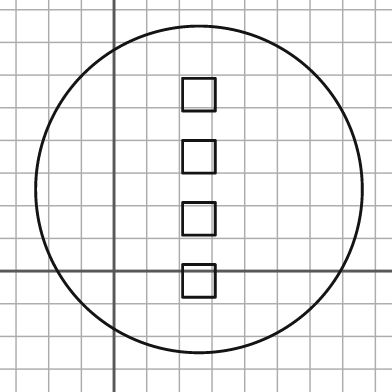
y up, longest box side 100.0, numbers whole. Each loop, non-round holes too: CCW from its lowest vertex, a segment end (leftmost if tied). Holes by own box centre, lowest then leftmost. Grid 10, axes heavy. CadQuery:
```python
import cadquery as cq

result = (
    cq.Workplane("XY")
    .moveTo(26.0, 25.0)
    .circle(50.0)
    .moveTo(21.0, -8.0)
    .lineTo(31.0, -8.0)
    .lineTo(31.0, 2.0)
    .lineTo(21.0, 2.0)
    .close()
    .moveTo(21.0, 11.0)
    .lineTo(31.0, 11.0)
    .lineTo(31.0, 21.0)
    .lineTo(21.0, 21.0)
    .close()
    .moveTo(21.0, 30.0)
    .lineTo(31.0, 30.0)
    .lineTo(31.0, 40.0)
    .lineTo(21.0, 40.0)
    .close()
    .moveTo(21.0, 49.0)
    .lineTo(31.0, 49.0)
    .lineTo(31.0, 59.0)
    .lineTo(21.0, 59.0)
    .close()
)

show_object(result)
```